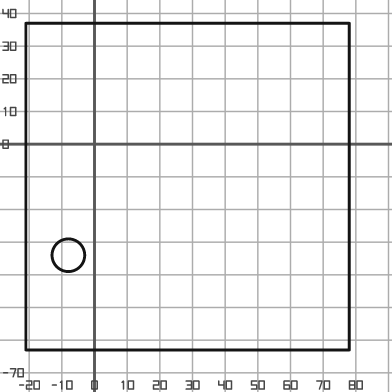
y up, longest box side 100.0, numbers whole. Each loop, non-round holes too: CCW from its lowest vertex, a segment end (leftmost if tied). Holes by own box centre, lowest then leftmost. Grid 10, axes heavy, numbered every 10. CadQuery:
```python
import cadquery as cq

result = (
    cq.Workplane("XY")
    .moveTo(-21.0, -63.0)
    .lineTo(78.0, -63.0)
    .lineTo(78.0, 37.0)
    .lineTo(-21.0, 37.0)
    .close()
    .moveTo(-8.0, -34.0)
    .circle(5.0)
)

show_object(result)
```